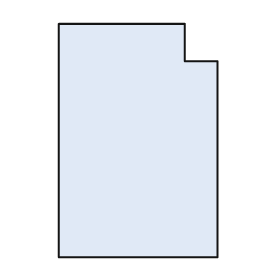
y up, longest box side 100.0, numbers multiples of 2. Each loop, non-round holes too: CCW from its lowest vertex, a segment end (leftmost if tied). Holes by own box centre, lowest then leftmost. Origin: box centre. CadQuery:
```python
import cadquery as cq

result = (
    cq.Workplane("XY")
    .moveTo(-34.0, -50.0)
    .lineTo(34.0, -50.0)
    .lineTo(34.0, 34.0)
    .lineTo(20.0, 34.0)
    .lineTo(20.0, 50.0)
    .lineTo(-34.0, 50.0)
    .close()
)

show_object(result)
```